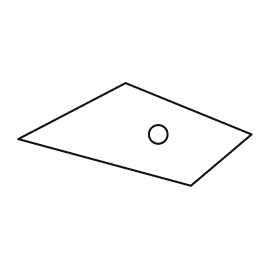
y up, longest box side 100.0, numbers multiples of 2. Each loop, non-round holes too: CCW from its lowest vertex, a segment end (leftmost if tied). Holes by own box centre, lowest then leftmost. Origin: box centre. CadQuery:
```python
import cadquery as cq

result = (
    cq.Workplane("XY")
    .moveTo(24.0, -22.0)
    .lineTo(50.0, 0.0)
    .lineTo(-4.0, 22.0)
    .lineTo(-50.0, -2.0)
    .close()
    .moveTo(10.0, 0.0)
    .circle(4.0)
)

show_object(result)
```